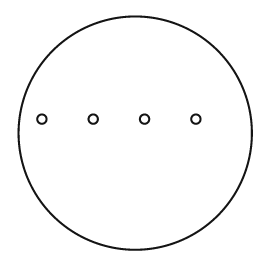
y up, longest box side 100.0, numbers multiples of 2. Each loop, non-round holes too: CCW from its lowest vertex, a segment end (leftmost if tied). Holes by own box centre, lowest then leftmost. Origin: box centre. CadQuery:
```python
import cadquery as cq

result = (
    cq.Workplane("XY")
    .moveTo(0.0, 0.0)
    .circle(50.0)
    .moveTo(-40.0, 6.0)
    .circle(2.0)
    .moveTo(-18.0, 6.0)
    .circle(2.0)
    .moveTo(4.0, 6.0)
    .circle(2.0)
    .moveTo(26.0, 6.0)
    .circle(2.0)
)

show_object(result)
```